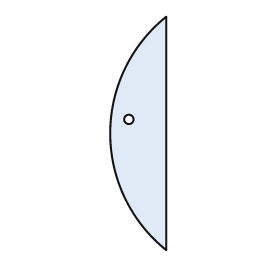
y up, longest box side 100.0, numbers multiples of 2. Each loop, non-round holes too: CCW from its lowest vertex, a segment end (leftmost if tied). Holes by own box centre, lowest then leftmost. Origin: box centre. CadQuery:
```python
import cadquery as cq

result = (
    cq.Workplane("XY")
    .moveTo(12.0, -50.0)
    .lineTo(12.0, 50.0)
    .threePointArc((-12.0, 0.0), (12.0, -50.0))
    .close()
    .moveTo(-4.0, 6.0)
    .circle(2.0)
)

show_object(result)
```